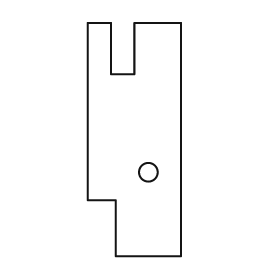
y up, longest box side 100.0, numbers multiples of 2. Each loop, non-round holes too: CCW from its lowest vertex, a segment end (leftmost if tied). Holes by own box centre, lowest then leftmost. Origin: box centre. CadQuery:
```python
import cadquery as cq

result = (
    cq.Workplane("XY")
    .moveTo(-8.0, -50.0)
    .lineTo(20.0, -50.0)
    .lineTo(20.0, 50.0)
    .lineTo(0.0, 50.0)
    .lineTo(0.0, 28.0)
    .lineTo(-10.0, 28.0)
    .lineTo(-10.0, 50.0)
    .lineTo(-20.0, 50.0)
    .lineTo(-20.0, -26.0)
    .lineTo(-8.0, -26.0)
    .close()
    .moveTo(6.0, -14.0)
    .circle(4.0)
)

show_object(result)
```